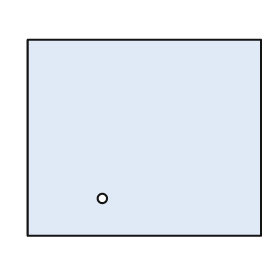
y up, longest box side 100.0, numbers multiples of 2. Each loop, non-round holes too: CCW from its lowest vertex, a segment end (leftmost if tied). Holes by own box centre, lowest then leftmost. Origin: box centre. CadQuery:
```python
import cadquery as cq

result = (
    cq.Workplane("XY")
    .moveTo(-50.0, -42.0)
    .lineTo(50.0, -42.0)
    .lineTo(50.0, 42.0)
    .lineTo(-50.0, 42.0)
    .close()
    .moveTo(-18.0, -26.0)
    .circle(2.0)
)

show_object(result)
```